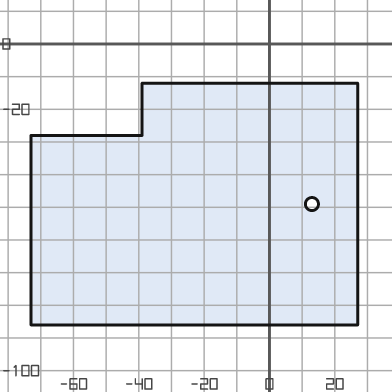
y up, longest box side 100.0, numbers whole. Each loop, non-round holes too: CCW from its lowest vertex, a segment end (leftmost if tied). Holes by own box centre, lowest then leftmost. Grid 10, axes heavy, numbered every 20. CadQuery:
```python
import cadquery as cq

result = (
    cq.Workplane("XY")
    .moveTo(-73.0, -86.0)
    .lineTo(27.0, -86.0)
    .lineTo(27.0, -12.0)
    .lineTo(-39.0, -12.0)
    .lineTo(-39.0, -28.0)
    .lineTo(-73.0, -28.0)
    .close()
    .moveTo(13.0, -49.0)
    .circle(2.0)
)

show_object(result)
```